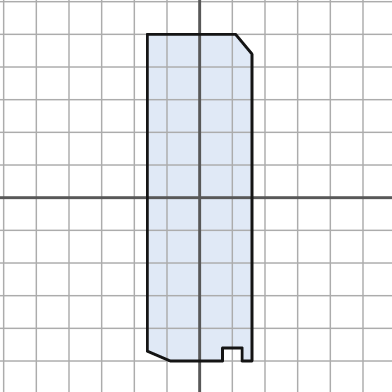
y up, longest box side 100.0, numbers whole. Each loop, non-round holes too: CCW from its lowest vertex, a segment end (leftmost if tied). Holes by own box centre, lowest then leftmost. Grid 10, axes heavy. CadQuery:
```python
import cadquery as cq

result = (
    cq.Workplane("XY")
    .moveTo(-9.0, -50.0)
    .lineTo(7.0, -50.0)
    .lineTo(7.0, -46.0)
    .lineTo(13.0, -46.0)
    .lineTo(13.0, -50.0)
    .lineTo(16.0, -50.0)
    .lineTo(16.0, 44.0)
    .lineTo(11.0, 50.0)
    .lineTo(-16.0, 50.0)
    .lineTo(-16.0, -47.0)
    .close()
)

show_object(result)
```